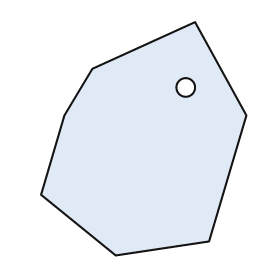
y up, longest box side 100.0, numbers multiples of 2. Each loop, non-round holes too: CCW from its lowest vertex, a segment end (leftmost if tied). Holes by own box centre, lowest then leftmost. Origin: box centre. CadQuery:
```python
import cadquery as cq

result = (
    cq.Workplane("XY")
    .moveTo(-12.0, -50.0)
    .lineTo(28.0, -44.0)
    .lineTo(44.0, 10.0)
    .lineTo(22.0, 50.0)
    .lineTo(-22.0, 30.0)
    .lineTo(-34.0, 10.0)
    .lineTo(-44.0, -24.0)
    .close()
    .moveTo(18.0, 22.0)
    .circle(4.0)
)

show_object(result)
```